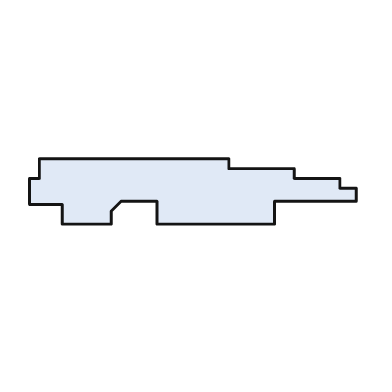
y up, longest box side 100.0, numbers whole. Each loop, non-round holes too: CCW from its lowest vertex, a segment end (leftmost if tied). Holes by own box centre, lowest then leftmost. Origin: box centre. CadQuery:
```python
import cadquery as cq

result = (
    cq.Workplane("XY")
    .moveTo(-40.0, -10.0)
    .lineTo(-25.0, -10.0)
    .lineTo(-25.0, -6.0)
    .lineTo(-22.0, -3.0)
    .lineTo(-11.0, -3.0)
    .lineTo(-11.0, -10.0)
    .lineTo(25.0, -10.0)
    .lineTo(25.0, -3.0)
    .lineTo(50.0, -3.0)
    .lineTo(50.0, 1.0)
    .lineTo(45.0, 1.0)
    .lineTo(45.0, 4.0)
    .lineTo(31.0, 4.0)
    .lineTo(31.0, 7.0)
    .lineTo(11.0, 7.0)
    .lineTo(11.0, 10.0)
    .lineTo(-47.0, 10.0)
    .lineTo(-47.0, 4.0)
    .lineTo(-50.0, 4.0)
    .lineTo(-50.0, -4.0)
    .lineTo(-40.0, -4.0)
    .close()
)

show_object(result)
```